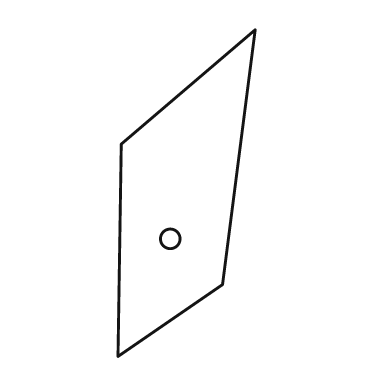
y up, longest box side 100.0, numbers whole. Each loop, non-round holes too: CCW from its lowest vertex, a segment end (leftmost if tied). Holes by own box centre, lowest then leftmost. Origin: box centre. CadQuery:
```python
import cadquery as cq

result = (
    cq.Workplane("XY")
    .moveTo(-21.0, -50.0)
    .lineTo(11.0, -28.0)
    .lineTo(21.0, 50.0)
    .lineTo(-20.0, 15.0)
    .close()
    .moveTo(-5.0, -14.0)
    .circle(3.0)
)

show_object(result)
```